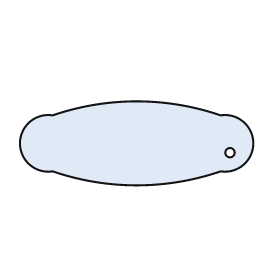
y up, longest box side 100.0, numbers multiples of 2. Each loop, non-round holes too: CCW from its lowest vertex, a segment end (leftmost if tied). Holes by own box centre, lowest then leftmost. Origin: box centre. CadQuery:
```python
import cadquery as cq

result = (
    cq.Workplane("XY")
    .moveTo(-36.0, -12.0)
    .threePointArc((0.0, -18.0), (36.0, -12.0))
    .threePointArc((50.0, 0.0), (36.0, 12.0))
    .threePointArc((0.0, 18.0), (-36.0, 12.0))
    .threePointArc((-50.0, 0.0), (-36.0, -12.0))
    .close()
    .moveTo(40.0, -4.0)
    .circle(2.0)
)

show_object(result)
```